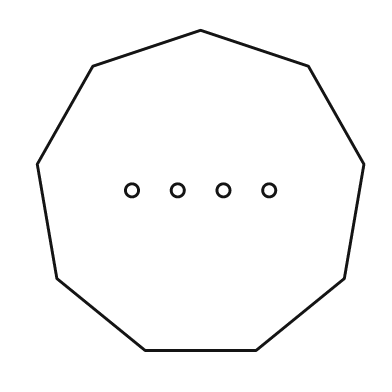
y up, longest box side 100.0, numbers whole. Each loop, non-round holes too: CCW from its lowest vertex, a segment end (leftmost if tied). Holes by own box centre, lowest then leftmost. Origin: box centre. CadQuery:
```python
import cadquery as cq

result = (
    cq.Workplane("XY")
    .moveTo(-17.0, -49.0)
    .lineTo(17.0, -49.0)
    .lineTo(44.0, -27.0)
    .lineTo(50.0, 8.0)
    .lineTo(33.0, 38.0)
    .lineTo(0.0, 49.0)
    .lineTo(-33.0, 38.0)
    .lineTo(-50.0, 8.0)
    .lineTo(-44.0, -27.0)
    .close()
    .moveTo(-21.0, 0.0)
    .circle(2.0)
    .moveTo(-7.0, 0.0)
    .circle(2.0)
    .moveTo(7.0, 0.0)
    .circle(2.0)
    .moveTo(21.0, 0.0)
    .circle(2.0)
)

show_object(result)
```